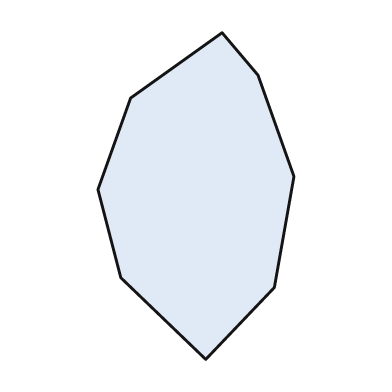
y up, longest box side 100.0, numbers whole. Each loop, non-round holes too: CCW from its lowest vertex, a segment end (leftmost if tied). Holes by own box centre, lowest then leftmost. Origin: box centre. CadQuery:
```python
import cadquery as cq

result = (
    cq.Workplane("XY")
    .moveTo(3.0, -50.0)
    .lineTo(24.0, -28.0)
    .lineTo(30.0, 6.0)
    .lineTo(19.0, 37.0)
    .lineTo(8.0, 50.0)
    .lineTo(-20.0, 30.0)
    .lineTo(-30.0, 2.0)
    .lineTo(-23.0, -25.0)
    .close()
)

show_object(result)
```